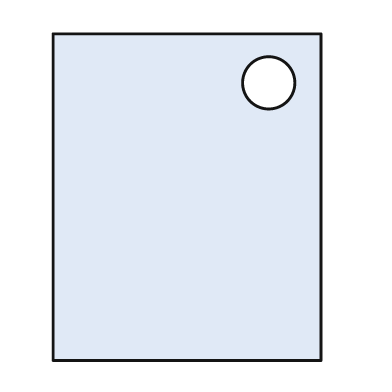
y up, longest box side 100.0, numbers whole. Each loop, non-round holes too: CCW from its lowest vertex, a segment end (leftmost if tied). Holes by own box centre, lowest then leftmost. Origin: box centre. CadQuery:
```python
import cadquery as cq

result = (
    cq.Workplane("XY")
    .moveTo(-41.0, -50.0)
    .lineTo(41.0, -50.0)
    .lineTo(41.0, 50.0)
    .lineTo(-41.0, 50.0)
    .close()
    .moveTo(25.0, 35.0)
    .circle(8.0)
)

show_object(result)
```